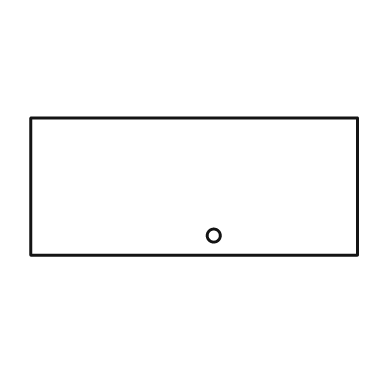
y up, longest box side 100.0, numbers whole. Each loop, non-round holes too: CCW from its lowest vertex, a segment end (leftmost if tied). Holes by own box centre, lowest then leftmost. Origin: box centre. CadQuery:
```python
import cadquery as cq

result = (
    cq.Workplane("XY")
    .moveTo(-50.0, -21.0)
    .lineTo(50.0, -21.0)
    .lineTo(50.0, 21.0)
    .lineTo(-50.0, 21.0)
    .close()
    .moveTo(6.0, -15.0)
    .circle(2.0)
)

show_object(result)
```